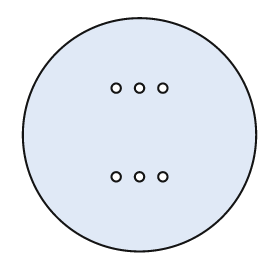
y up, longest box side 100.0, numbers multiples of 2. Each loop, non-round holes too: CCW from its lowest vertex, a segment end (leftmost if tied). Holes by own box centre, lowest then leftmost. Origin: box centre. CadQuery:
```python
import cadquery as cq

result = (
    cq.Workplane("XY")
    .moveTo(0.0, 0.0)
    .circle(50.0)
    .moveTo(-10.0, -18.0)
    .circle(2.0)
    .moveTo(0.0, -18.0)
    .circle(2.0)
    .moveTo(10.0, -18.0)
    .circle(2.0)
    .moveTo(-10.0, 20.0)
    .circle(2.0)
    .moveTo(0.0, 20.0)
    .circle(2.0)
    .moveTo(10.0, 20.0)
    .circle(2.0)
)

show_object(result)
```